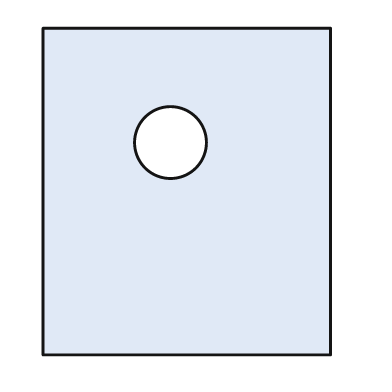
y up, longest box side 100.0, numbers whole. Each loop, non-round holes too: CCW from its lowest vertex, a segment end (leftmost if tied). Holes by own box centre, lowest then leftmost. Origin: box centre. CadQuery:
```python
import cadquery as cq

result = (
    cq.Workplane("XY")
    .moveTo(-44.0, -50.0)
    .lineTo(44.0, -50.0)
    .lineTo(44.0, 50.0)
    .lineTo(-44.0, 50.0)
    .close()
    .moveTo(-5.0, 15.0)
    .circle(11.0)
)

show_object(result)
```